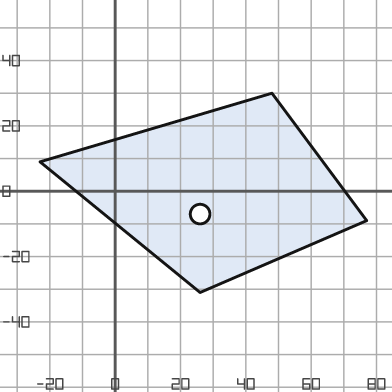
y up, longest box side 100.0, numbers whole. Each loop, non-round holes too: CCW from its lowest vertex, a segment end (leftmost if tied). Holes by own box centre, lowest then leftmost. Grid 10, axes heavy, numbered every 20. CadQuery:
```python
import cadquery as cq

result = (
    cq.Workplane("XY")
    .moveTo(26.0, -31.0)
    .lineTo(77.0, -9.0)
    .lineTo(48.0, 30.0)
    .lineTo(-23.0, 9.0)
    .close()
    .moveTo(26.0, -7.0)
    .circle(3.0)
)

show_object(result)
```